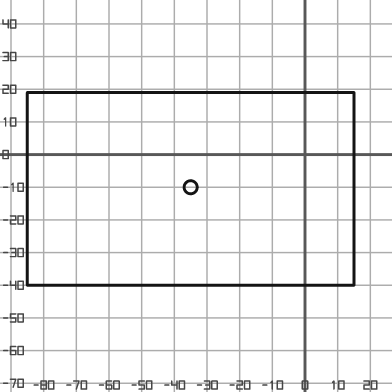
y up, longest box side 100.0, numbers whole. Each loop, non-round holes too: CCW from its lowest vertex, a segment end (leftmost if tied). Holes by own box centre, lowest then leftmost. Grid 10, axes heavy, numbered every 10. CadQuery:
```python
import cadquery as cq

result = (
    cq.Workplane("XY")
    .moveTo(-85.0, -40.0)
    .lineTo(15.0, -40.0)
    .lineTo(15.0, 19.0)
    .lineTo(-85.0, 19.0)
    .close()
    .moveTo(-35.0, -10.0)
    .circle(2.0)
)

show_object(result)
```